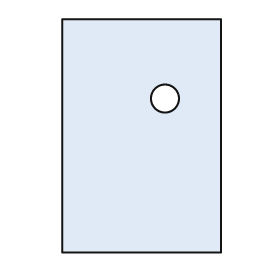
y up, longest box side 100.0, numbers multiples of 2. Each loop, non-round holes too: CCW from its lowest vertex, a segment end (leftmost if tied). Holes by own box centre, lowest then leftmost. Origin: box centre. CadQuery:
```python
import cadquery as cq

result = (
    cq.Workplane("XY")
    .moveTo(-34.0, -50.0)
    .lineTo(34.0, -50.0)
    .lineTo(34.0, 50.0)
    .lineTo(-34.0, 50.0)
    .close()
    .moveTo(10.0, 16.0)
    .circle(6.0)
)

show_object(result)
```